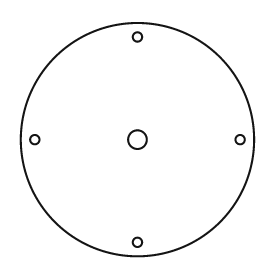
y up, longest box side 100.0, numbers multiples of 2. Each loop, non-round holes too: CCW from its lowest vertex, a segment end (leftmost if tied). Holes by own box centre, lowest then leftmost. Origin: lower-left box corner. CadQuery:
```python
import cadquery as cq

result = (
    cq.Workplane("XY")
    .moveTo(50.0, 50.0)
    .circle(50.0)
    .moveTo(50.0, 6.0)
    .circle(2.0)
    .moveTo(6.0, 50.0)
    .circle(2.0)
    .moveTo(50.0, 50.0)
    .circle(4.0)
    .moveTo(94.0, 50.0)
    .circle(2.0)
    .moveTo(50.0, 94.0)
    .circle(2.0)
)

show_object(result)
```